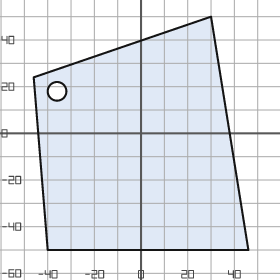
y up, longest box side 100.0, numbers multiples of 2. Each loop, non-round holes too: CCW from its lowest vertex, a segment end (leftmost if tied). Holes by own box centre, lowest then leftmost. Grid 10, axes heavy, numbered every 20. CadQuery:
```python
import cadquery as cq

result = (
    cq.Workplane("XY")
    .moveTo(-40.0, -50.0)
    .lineTo(46.0, -50.0)
    .lineTo(30.0, 50.0)
    .lineTo(-46.0, 24.0)
    .close()
    .moveTo(-36.0, 18.0)
    .circle(4.0)
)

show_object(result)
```